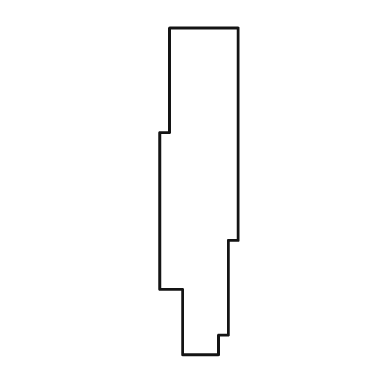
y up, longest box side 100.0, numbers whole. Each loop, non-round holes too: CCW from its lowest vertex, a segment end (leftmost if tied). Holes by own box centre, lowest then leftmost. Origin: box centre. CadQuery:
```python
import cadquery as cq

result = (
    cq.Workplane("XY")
    .moveTo(-5.0, -50.0)
    .lineTo(6.0, -50.0)
    .lineTo(6.0, -44.0)
    .lineTo(9.0, -44.0)
    .lineTo(9.0, -15.0)
    .lineTo(12.0, -15.0)
    .lineTo(12.0, 50.0)
    .lineTo(-9.0, 50.0)
    .lineTo(-9.0, 18.0)
    .lineTo(-12.0, 18.0)
    .lineTo(-12.0, -30.0)
    .lineTo(-5.0, -30.0)
    .close()
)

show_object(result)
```